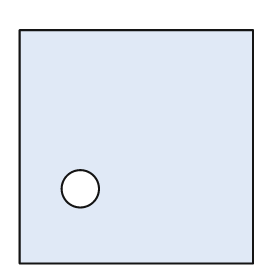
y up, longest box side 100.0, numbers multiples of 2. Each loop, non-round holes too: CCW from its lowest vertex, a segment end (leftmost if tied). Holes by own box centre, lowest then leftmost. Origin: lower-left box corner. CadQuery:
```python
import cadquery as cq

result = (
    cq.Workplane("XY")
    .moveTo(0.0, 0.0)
    .lineTo(100.0, 0.0)
    .lineTo(100.0, 100.0)
    .lineTo(0.0, 100.0)
    .close()
    .moveTo(26.0, 32.0)
    .circle(8.0)
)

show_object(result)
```